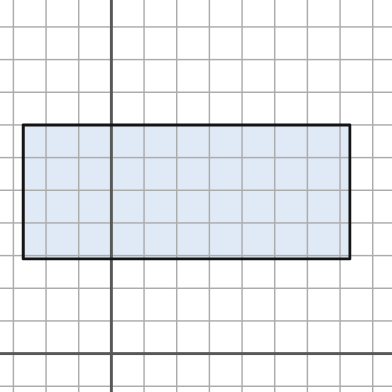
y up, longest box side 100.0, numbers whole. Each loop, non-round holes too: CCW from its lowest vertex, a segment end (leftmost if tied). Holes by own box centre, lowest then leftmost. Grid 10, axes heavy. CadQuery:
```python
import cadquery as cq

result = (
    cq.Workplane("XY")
    .moveTo(-27.0, 29.0)
    .lineTo(73.0, 29.0)
    .lineTo(73.0, 70.0)
    .lineTo(-27.0, 70.0)
    .close()
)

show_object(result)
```